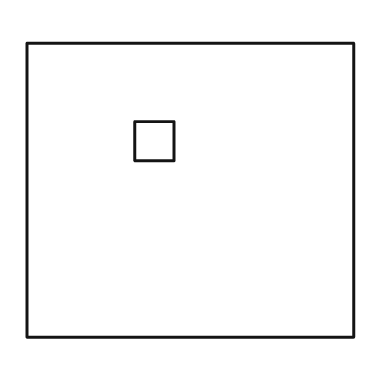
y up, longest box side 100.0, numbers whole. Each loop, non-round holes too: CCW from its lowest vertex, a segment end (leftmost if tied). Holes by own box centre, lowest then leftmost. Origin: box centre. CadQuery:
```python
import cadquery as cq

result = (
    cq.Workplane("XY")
    .moveTo(-50.0, -45.0)
    .lineTo(50.0, -45.0)
    .lineTo(50.0, 45.0)
    .lineTo(-50.0, 45.0)
    .close()
    .moveTo(-17.0, 9.0)
    .lineTo(-5.0, 9.0)
    .lineTo(-5.0, 21.0)
    .lineTo(-17.0, 21.0)
    .close()
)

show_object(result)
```